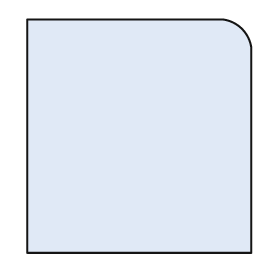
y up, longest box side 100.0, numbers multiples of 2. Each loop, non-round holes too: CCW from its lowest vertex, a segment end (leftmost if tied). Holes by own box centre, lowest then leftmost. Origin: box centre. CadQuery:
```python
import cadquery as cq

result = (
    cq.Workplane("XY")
    .moveTo(-48.0, -50.0)
    .lineTo(48.0, -50.0)
    .lineTo(48.0, 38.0)
    .threePointArc((44.0, 46.0), (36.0, 50.0))
    .lineTo(-48.0, 50.0)
    .close()
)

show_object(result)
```